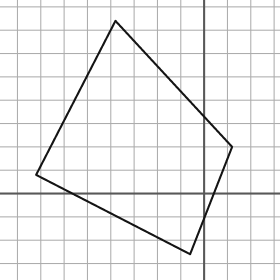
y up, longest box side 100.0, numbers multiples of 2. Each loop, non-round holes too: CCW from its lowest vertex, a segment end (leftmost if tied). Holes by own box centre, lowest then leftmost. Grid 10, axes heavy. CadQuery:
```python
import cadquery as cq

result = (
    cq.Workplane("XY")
    .moveTo(-6.0, -26.0)
    .lineTo(12.0, 20.0)
    .lineTo(-38.0, 74.0)
    .lineTo(-72.0, 8.0)
    .close()
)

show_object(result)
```